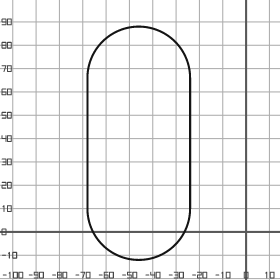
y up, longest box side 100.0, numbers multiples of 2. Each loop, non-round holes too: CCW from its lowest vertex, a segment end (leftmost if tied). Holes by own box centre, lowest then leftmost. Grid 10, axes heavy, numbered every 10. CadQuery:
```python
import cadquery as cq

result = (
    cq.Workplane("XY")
    .moveTo(-68.0, 10.0)
    .threePointArc((-46.0, -12.0), (-24.0, 10.0))
    .lineTo(-24.0, 66.0)
    .threePointArc((-46.0, 88.0), (-68.0, 66.0))
    .close()
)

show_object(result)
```